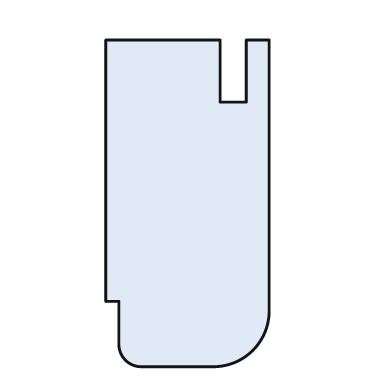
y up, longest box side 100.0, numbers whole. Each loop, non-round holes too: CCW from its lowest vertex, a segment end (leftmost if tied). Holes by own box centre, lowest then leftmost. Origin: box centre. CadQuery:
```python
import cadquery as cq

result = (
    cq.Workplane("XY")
    .moveTo(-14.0, -50.0)
    .lineTo(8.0, -50.0)
    .threePointArc((20.0, -45.0), (25.0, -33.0))
    .lineTo(25.0, 50.0)
    .lineTo(18.0, 50.0)
    .lineTo(18.0, 31.0)
    .lineTo(10.0, 31.0)
    .lineTo(10.0, 50.0)
    .lineTo(-25.0, 50.0)
    .lineTo(-25.0, -30.0)
    .lineTo(-21.0, -30.0)
    .lineTo(-21.0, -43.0)
    .threePointArc((-19.0, -48.0), (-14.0, -50.0))
    .close()
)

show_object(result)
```